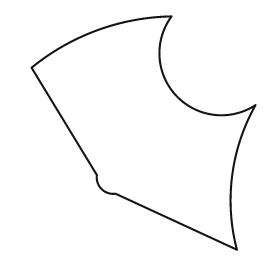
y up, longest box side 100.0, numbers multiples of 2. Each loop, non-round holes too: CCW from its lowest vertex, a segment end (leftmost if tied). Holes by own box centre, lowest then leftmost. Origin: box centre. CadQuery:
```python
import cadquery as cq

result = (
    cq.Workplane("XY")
    .moveTo(40.0, -50.0)
    .threePointArc((38.0, -18.0), (48.0, 12.0))
    .threePointArc((14.0, 16.0), (12.0, 50.0))
    .threePointArc((-20.0, 44.0), (-48.0, 28.0))
    .lineTo(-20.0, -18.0)
    .threePointArc((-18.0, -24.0), (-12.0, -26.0))
    .close()
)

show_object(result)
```